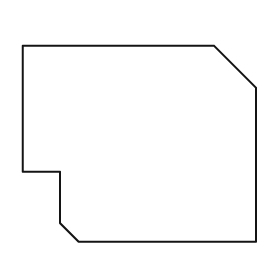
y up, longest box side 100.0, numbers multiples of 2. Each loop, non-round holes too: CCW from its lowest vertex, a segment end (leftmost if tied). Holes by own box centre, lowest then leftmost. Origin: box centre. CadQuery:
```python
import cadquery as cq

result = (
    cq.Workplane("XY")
    .moveTo(-26.0, -42.0)
    .lineTo(50.0, -42.0)
    .lineTo(50.0, 24.0)
    .lineTo(32.0, 42.0)
    .lineTo(-50.0, 42.0)
    .lineTo(-50.0, -12.0)
    .lineTo(-34.0, -12.0)
    .lineTo(-34.0, -34.0)
    .close()
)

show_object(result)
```